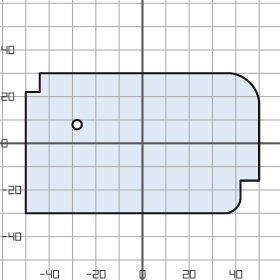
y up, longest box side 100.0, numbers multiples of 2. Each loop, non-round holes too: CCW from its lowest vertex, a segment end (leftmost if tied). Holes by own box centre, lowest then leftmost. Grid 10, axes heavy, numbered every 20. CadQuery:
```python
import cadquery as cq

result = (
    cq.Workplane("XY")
    .moveTo(-50.0, -30.0)
    .lineTo(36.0, -30.0)
    .threePointArc((40.0, -28.0), (42.0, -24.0))
    .lineTo(42.0, -16.0)
    .lineTo(50.0, -16.0)
    .lineTo(50.0, 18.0)
    .threePointArc((46.0, 26.0), (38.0, 30.0))
    .lineTo(-44.0, 30.0)
    .lineTo(-44.0, 22.0)
    .lineTo(-50.0, 22.0)
    .close()
    .moveTo(-28.0, 8.0)
    .circle(2.0)
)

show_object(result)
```